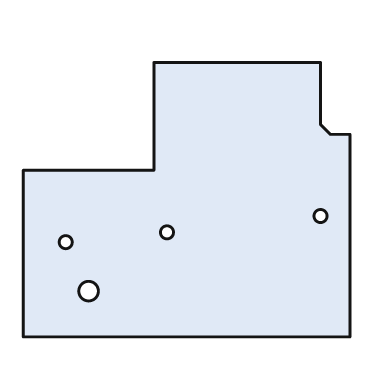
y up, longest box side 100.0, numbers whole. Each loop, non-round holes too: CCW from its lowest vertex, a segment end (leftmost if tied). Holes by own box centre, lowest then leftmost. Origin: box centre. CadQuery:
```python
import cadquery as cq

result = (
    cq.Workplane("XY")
    .moveTo(-50.0, -42.0)
    .lineTo(50.0, -42.0)
    .lineTo(50.0, 20.0)
    .lineTo(44.0, 20.0)
    .lineTo(41.0, 23.0)
    .lineTo(41.0, 42.0)
    .lineTo(-10.0, 42.0)
    .lineTo(-10.0, 9.0)
    .lineTo(-50.0, 9.0)
    .close()
    .moveTo(-30.0, -28.0)
    .circle(3.0)
    .moveTo(-37.0, -13.0)
    .circle(2.0)
    .moveTo(-6.0, -10.0)
    .circle(2.0)
    .moveTo(41.0, -5.0)
    .circle(2.0)
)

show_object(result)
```